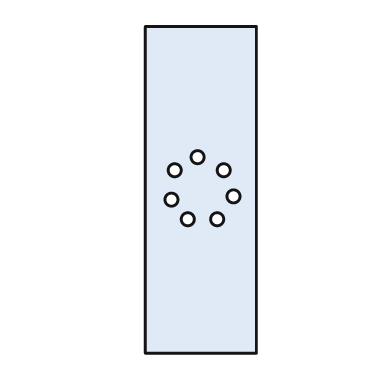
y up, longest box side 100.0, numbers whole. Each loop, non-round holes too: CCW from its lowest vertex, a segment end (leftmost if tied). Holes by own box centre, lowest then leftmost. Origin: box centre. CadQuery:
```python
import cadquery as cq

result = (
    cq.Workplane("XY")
    .moveTo(-17.0, -50.0)
    .lineTo(17.0, -50.0)
    .lineTo(17.0, 50.0)
    .lineTo(-17.0, 50.0)
    .close()
    .moveTo(-4.0, -9.0)
    .circle(2.0)
    .moveTo(5.0, -9.0)
    .circle(2.0)
    .moveTo(-9.0, -3.0)
    .circle(2.0)
    .moveTo(10.0, -2.0)
    .circle(2.0)
    .moveTo(-8.0, 6.0)
    .circle(2.0)
    .moveTo(7.0, 6.0)
    .circle(2.0)
    .moveTo(-1.0, 10.0)
    .circle(2.0)
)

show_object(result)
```